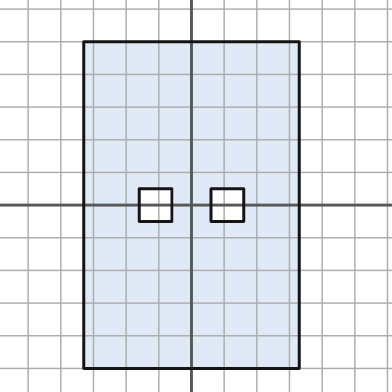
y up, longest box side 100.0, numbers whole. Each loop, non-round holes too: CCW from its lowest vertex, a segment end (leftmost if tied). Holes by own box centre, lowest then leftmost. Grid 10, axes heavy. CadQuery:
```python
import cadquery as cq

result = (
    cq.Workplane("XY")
    .moveTo(-33.0, -50.0)
    .lineTo(33.0, -50.0)
    .lineTo(33.0, 50.0)
    .lineTo(-33.0, 50.0)
    .close()
    .moveTo(-16.0, -5.0)
    .lineTo(-6.0, -5.0)
    .lineTo(-6.0, 5.0)
    .lineTo(-16.0, 5.0)
    .close()
    .moveTo(6.0, -5.0)
    .lineTo(16.0, -5.0)
    .lineTo(16.0, 5.0)
    .lineTo(6.0, 5.0)
    .close()
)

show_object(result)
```